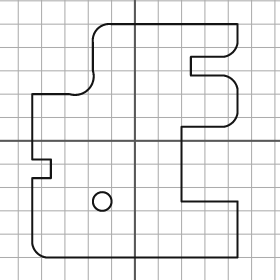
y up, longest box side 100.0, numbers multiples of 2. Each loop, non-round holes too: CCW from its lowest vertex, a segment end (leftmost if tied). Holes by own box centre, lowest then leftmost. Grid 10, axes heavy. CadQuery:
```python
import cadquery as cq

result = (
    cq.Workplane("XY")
    .moveTo(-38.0, -50.0)
    .lineTo(44.0, -50.0)
    .lineTo(44.0, -26.0)
    .lineTo(20.0, -26.0)
    .lineTo(20.0, 6.0)
    .lineTo(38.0, 6.0)
    .threePointArc((42.0, 8.0), (44.0, 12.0))
    .lineTo(44.0, 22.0)
    .threePointArc((42.0, 26.0), (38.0, 28.0))
    .lineTo(24.0, 28.0)
    .lineTo(24.0, 36.0)
    .lineTo(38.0, 36.0)
    .threePointArc((42.0, 38.0), (44.0, 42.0))
    .lineTo(44.0, 50.0)
    .lineTo(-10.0, 50.0)
    .threePointArc((-16.0, 48.0), (-18.0, 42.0))
    .lineTo(-18.0, 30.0)
    .threePointArc((-20.0, 22.0), (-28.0, 20.0))
    .lineTo(-44.0, 20.0)
    .lineTo(-44.0, -8.0)
    .lineTo(-36.0, -8.0)
    .lineTo(-36.0, -16.0)
    .lineTo(-44.0, -16.0)
    .lineTo(-44.0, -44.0)
    .threePointArc((-42.0, -48.0), (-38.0, -50.0))
    .close()
    .moveTo(-14.0, -26.0)
    .circle(4.0)
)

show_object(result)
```